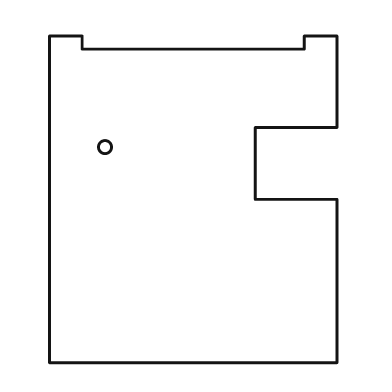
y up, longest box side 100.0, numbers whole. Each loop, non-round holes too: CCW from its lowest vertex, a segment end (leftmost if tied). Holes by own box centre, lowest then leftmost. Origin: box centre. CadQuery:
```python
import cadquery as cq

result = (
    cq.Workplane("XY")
    .moveTo(-44.0, -50.0)
    .lineTo(44.0, -50.0)
    .lineTo(44.0, 0.0)
    .lineTo(19.0, 0.0)
    .lineTo(19.0, 22.0)
    .lineTo(44.0, 22.0)
    .lineTo(44.0, 50.0)
    .lineTo(34.0, 50.0)
    .lineTo(34.0, 46.0)
    .lineTo(-34.0, 46.0)
    .lineTo(-34.0, 50.0)
    .lineTo(-44.0, 50.0)
    .close()
    .moveTo(-27.0, 16.0)
    .circle(2.0)
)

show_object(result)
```